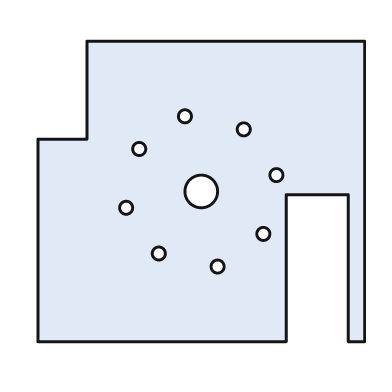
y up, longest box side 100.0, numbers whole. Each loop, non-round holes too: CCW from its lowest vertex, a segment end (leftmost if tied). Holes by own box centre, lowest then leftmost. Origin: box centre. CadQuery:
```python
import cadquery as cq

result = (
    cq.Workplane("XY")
    .moveTo(-50.0, -46.0)
    .lineTo(26.0, -46.0)
    .lineTo(26.0, -1.0)
    .lineTo(45.0, -1.0)
    .lineTo(45.0, -46.0)
    .lineTo(50.0, -46.0)
    .lineTo(50.0, 46.0)
    .lineTo(-35.0, 46.0)
    .lineTo(-35.0, 16.0)
    .lineTo(-50.0, 16.0)
    .close()
    .moveTo(5.0, -23.0)
    .circle(2.0)
    .moveTo(-13.0, -19.0)
    .circle(2.0)
    .moveTo(19.0, -13.0)
    .circle(2.0)
    .moveTo(-23.0, -5.0)
    .circle(2.0)
    .moveTo(0.0, 0.0)
    .circle(5.0)
    .moveTo(23.0, 5.0)
    .circle(2.0)
    .moveTo(-19.0, 13.0)
    .circle(2.0)
    .moveTo(13.0, 19.0)
    .circle(2.0)
    .moveTo(-5.0, 23.0)
    .circle(2.0)
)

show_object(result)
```